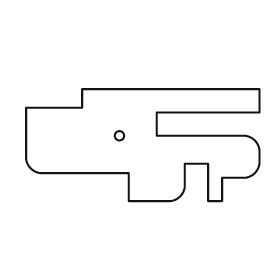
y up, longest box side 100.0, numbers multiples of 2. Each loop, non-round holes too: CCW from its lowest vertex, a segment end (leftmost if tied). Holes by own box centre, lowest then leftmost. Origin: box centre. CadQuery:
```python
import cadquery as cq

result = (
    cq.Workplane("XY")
    .moveTo(-6.0, -24.0)
    .lineTo(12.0, -24.0)
    .threePointArc((16.0, -22.0), (18.0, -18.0))
    .lineTo(18.0, -8.0)
    .lineTo(28.0, -8.0)
    .lineTo(28.0, -24.0)
    .lineTo(34.0, -24.0)
    .lineTo(34.0, -14.0)
    .lineTo(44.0, -14.0)
    .threePointArc((48.0, -12.0), (50.0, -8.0))
    .lineTo(50.0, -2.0)
    .threePointArc((48.0, 2.0), (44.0, 4.0))
    .lineTo(6.0, 4.0)
    .lineTo(6.0, 14.0)
    .lineTo(50.0, 14.0)
    .lineTo(50.0, 24.0)
    .lineTo(-26.0, 24.0)
    .lineTo(-26.0, 16.0)
    .lineTo(-50.0, 16.0)
    .lineTo(-50.0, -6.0)
    .threePointArc((-48.0, -10.0), (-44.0, -12.0))
    .lineTo(-6.0, -12.0)
    .close()
    .moveTo(-10.0, 4.0)
    .circle(2.0)
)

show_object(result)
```